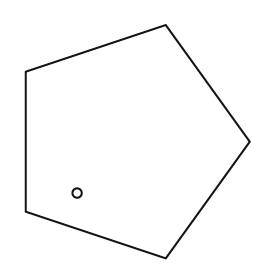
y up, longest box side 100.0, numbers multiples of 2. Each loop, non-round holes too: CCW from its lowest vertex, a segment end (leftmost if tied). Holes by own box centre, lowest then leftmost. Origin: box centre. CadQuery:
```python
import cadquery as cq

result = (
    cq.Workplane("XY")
    .moveTo(12.0, -50.0)
    .lineTo(48.0, 0.0)
    .lineTo(12.0, 50.0)
    .lineTo(-48.0, 30.0)
    .lineTo(-48.0, -30.0)
    .close()
    .moveTo(-26.0, -22.0)
    .circle(2.0)
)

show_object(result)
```